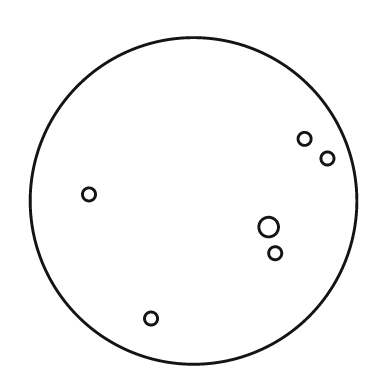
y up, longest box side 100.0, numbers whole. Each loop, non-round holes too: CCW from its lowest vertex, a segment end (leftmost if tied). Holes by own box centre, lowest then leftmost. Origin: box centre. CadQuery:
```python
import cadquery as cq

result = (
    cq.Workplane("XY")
    .moveTo(0.0, 0.0)
    .circle(50.0)
    .moveTo(-13.0, -36.0)
    .circle(2.0)
    .moveTo(25.0, -16.0)
    .circle(2.0)
    .moveTo(23.0, -8.0)
    .circle(3.0)
    .moveTo(-32.0, 2.0)
    .circle(2.0)
    .moveTo(41.0, 13.0)
    .circle(2.0)
    .moveTo(34.0, 19.0)
    .circle(2.0)
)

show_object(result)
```